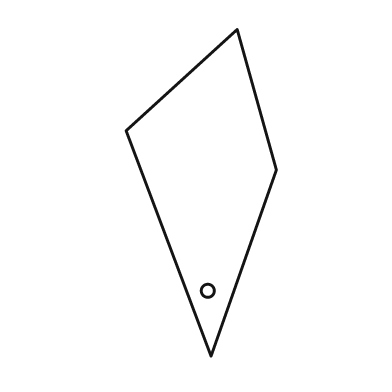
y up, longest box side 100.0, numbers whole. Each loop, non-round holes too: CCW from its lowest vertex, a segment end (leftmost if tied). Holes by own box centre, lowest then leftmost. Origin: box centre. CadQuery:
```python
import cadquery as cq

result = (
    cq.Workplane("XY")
    .moveTo(3.0, -50.0)
    .lineTo(23.0, 7.0)
    .lineTo(11.0, 50.0)
    .lineTo(-23.0, 19.0)
    .close()
    .moveTo(2.0, -30.0)
    .circle(2.0)
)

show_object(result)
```